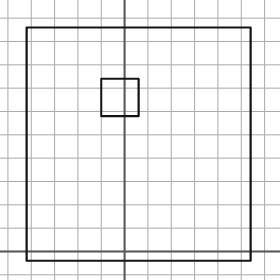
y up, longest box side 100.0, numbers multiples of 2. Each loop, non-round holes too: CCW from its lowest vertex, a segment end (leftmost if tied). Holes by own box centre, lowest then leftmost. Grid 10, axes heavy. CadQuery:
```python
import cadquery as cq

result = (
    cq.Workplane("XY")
    .moveTo(-42.0, -4.0)
    .lineTo(54.0, -4.0)
    .lineTo(54.0, 96.0)
    .lineTo(-42.0, 96.0)
    .close()
    .moveTo(-10.0, 58.0)
    .lineTo(6.0, 58.0)
    .lineTo(6.0, 74.0)
    .lineTo(-10.0, 74.0)
    .close()
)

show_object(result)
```